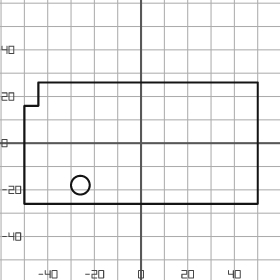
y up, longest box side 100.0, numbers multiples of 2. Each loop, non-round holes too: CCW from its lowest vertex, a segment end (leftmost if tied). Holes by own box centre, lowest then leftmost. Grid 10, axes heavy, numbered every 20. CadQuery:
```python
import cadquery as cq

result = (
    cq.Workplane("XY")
    .moveTo(-50.0, -26.0)
    .lineTo(50.0, -26.0)
    .lineTo(50.0, 26.0)
    .lineTo(-44.0, 26.0)
    .lineTo(-44.0, 16.0)
    .lineTo(-50.0, 16.0)
    .close()
    .moveTo(-26.0, -18.0)
    .circle(4.0)
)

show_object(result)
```